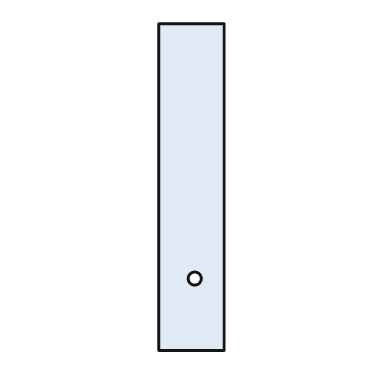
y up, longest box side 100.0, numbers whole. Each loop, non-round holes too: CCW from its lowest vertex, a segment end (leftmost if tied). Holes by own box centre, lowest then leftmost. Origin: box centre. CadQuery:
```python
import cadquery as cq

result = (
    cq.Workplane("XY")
    .moveTo(-10.0, -50.0)
    .lineTo(10.0, -50.0)
    .lineTo(10.0, 50.0)
    .lineTo(-10.0, 50.0)
    .close()
    .moveTo(1.0, -28.0)
    .circle(2.0)
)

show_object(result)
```